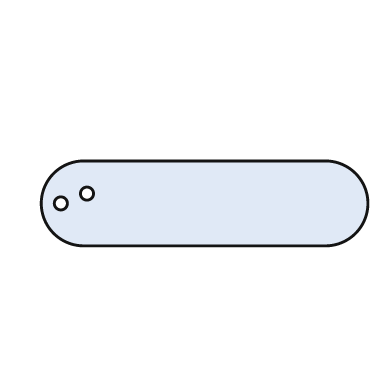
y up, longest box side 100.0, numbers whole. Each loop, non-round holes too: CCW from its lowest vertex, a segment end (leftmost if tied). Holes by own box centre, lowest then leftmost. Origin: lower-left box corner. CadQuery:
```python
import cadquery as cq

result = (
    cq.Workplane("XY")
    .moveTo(13.0, 0.0)
    .lineTo(87.0, 0.0)
    .threePointArc((100.0, 13.0), (87.0, 26.0))
    .lineTo(13.0, 26.0)
    .threePointArc((0.0, 13.0), (13.0, 0.0))
    .close()
    .moveTo(6.0, 13.0)
    .circle(2.0)
    .moveTo(14.0, 16.0)
    .circle(2.0)
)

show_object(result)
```